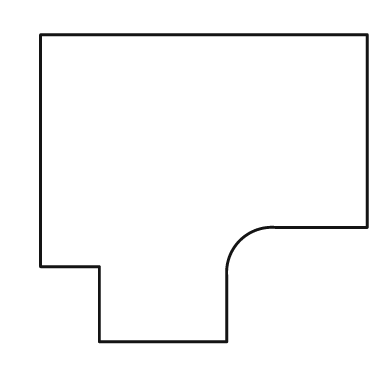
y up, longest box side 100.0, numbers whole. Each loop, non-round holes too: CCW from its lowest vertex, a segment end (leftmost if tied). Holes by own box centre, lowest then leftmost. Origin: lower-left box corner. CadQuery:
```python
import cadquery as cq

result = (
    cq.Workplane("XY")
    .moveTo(18.0, 0.0)
    .lineTo(57.0, 0.0)
    .lineTo(57.0, 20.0)
    .threePointArc((61.0, 31.0), (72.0, 35.0))
    .lineTo(100.0, 35.0)
    .lineTo(100.0, 94.0)
    .lineTo(0.0, 94.0)
    .lineTo(0.0, 23.0)
    .lineTo(18.0, 23.0)
    .close()
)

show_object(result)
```